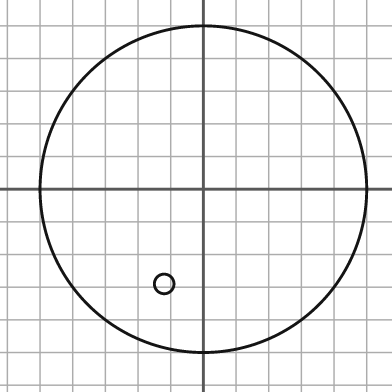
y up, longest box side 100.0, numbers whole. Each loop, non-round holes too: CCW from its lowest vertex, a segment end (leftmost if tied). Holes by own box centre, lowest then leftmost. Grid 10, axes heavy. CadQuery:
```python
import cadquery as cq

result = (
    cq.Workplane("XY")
    .moveTo(0.0, 0.0)
    .circle(50.0)
    .moveTo(-12.0, -29.0)
    .circle(3.0)
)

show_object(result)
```